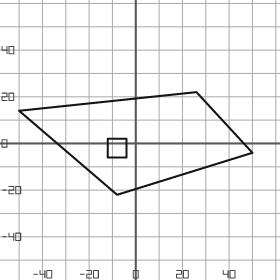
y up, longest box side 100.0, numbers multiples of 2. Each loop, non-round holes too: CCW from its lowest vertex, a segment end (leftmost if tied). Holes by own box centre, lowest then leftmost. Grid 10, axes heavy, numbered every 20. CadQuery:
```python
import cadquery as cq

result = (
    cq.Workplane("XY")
    .moveTo(-8.0, -22.0)
    .lineTo(50.0, -4.0)
    .lineTo(26.0, 22.0)
    .lineTo(-50.0, 14.0)
    .close()
    .moveTo(-12.0, -6.0)
    .lineTo(-4.0, -6.0)
    .lineTo(-4.0, 2.0)
    .lineTo(-12.0, 2.0)
    .close()
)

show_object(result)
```